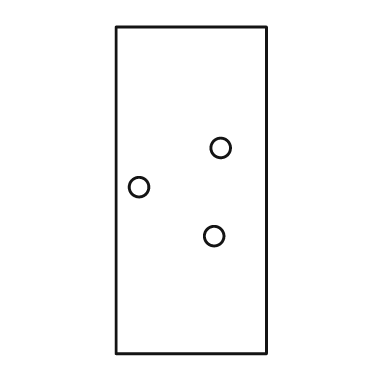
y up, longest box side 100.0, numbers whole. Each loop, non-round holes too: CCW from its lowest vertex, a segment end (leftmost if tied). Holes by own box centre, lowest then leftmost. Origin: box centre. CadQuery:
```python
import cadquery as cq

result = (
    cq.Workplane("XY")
    .moveTo(-23.0, -50.0)
    .lineTo(23.0, -50.0)
    .lineTo(23.0, 50.0)
    .lineTo(-23.0, 50.0)
    .close()
    .moveTo(7.0, -14.0)
    .circle(3.0)
    .moveTo(-16.0, 1.0)
    .circle(3.0)
    .moveTo(9.0, 13.0)
    .circle(3.0)
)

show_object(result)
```